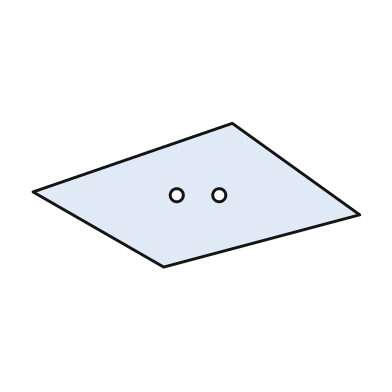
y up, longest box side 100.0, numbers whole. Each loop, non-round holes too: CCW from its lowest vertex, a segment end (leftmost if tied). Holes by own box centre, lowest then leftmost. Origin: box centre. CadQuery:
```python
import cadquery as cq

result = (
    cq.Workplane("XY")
    .moveTo(-10.0, -22.0)
    .lineTo(50.0, -6.0)
    .lineTo(11.0, 22.0)
    .lineTo(-50.0, 1.0)
    .close()
    .moveTo(-6.0, 0.0)
    .circle(2.0)
    .moveTo(7.0, 0.0)
    .circle(2.0)
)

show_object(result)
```